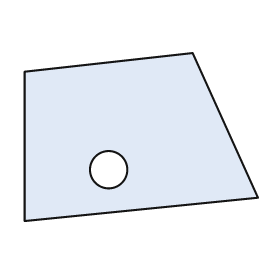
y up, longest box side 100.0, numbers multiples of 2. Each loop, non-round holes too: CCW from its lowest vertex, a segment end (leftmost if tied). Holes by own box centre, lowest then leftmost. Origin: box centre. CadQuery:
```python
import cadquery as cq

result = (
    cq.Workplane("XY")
    .moveTo(-50.0, -36.0)
    .lineTo(50.0, -26.0)
    .lineTo(22.0, 36.0)
    .lineTo(-50.0, 28.0)
    .close()
    .moveTo(-14.0, -14.0)
    .circle(8.0)
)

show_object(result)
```